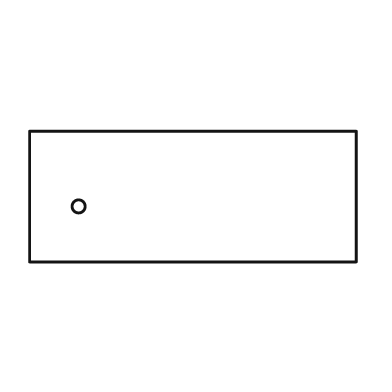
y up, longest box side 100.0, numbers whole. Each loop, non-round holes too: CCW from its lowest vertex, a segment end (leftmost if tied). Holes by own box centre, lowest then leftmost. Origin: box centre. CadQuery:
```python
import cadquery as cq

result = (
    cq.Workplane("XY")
    .moveTo(-50.0, -20.0)
    .lineTo(50.0, -20.0)
    .lineTo(50.0, 20.0)
    .lineTo(-50.0, 20.0)
    .close()
    .moveTo(-35.0, -3.0)
    .circle(2.0)
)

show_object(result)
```